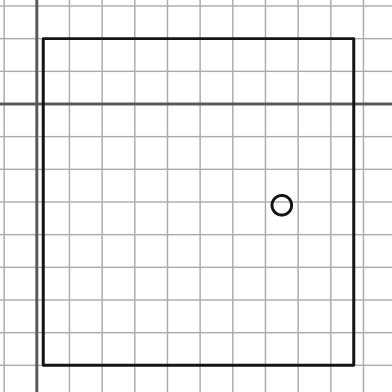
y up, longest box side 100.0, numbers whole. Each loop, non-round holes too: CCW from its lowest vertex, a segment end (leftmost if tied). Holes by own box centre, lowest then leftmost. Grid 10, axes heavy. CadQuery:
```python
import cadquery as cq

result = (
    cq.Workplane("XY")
    .moveTo(2.0, -80.0)
    .lineTo(97.0, -80.0)
    .lineTo(97.0, 20.0)
    .lineTo(2.0, 20.0)
    .close()
    .moveTo(75.0, -31.0)
    .circle(3.0)
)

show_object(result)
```